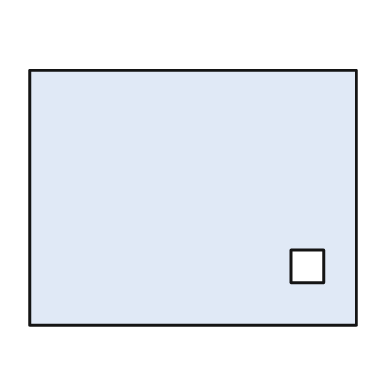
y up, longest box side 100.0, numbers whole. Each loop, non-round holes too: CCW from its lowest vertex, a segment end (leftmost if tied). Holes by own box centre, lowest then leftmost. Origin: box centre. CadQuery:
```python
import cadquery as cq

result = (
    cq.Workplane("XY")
    .moveTo(-50.0, -39.0)
    .lineTo(50.0, -39.0)
    .lineTo(50.0, 39.0)
    .lineTo(-50.0, 39.0)
    .close()
    .moveTo(30.0, -26.0)
    .lineTo(40.0, -26.0)
    .lineTo(40.0, -16.0)
    .lineTo(30.0, -16.0)
    .close()
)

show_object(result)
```